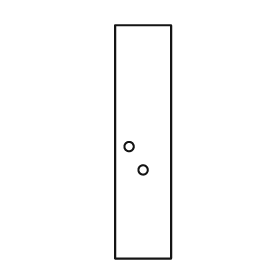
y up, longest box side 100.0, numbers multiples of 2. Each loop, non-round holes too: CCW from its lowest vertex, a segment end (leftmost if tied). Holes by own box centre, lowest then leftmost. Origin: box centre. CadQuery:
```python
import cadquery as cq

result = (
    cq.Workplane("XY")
    .moveTo(-12.0, -50.0)
    .lineTo(12.0, -50.0)
    .lineTo(12.0, 50.0)
    .lineTo(-12.0, 50.0)
    .close()
    .moveTo(0.0, -12.0)
    .circle(2.0)
    .moveTo(-6.0, -2.0)
    .circle(2.0)
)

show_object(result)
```